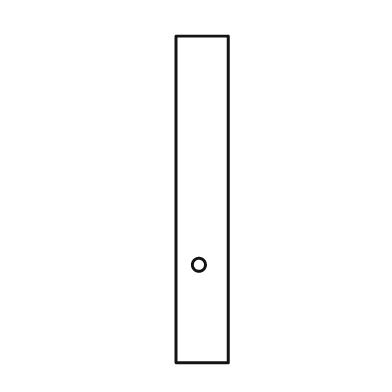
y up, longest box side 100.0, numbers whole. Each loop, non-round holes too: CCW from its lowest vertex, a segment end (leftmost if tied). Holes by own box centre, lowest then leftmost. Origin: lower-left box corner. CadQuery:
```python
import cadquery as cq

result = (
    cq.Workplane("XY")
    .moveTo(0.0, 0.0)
    .lineTo(16.0, 0.0)
    .lineTo(16.0, 100.0)
    .lineTo(0.0, 100.0)
    .close()
    .moveTo(7.0, 30.0)
    .circle(2.0)
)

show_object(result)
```